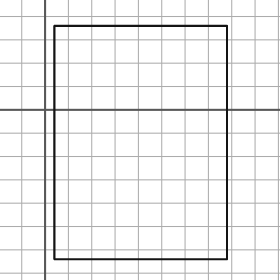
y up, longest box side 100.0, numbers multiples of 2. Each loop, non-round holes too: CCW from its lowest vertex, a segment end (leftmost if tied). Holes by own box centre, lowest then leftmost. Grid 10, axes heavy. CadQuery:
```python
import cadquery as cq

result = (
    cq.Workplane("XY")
    .moveTo(4.0, -64.0)
    .lineTo(78.0, -64.0)
    .lineTo(78.0, 36.0)
    .lineTo(4.0, 36.0)
    .close()
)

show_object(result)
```